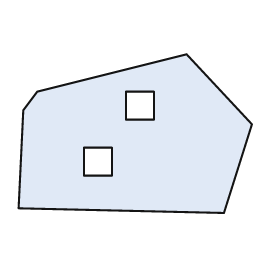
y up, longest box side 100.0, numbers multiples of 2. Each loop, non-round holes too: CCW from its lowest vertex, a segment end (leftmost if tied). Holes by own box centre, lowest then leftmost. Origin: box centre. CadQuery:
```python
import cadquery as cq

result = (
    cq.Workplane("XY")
    .moveTo(38.0, -34.0)
    .lineTo(50.0, 4.0)
    .lineTo(22.0, 34.0)
    .lineTo(-42.0, 18.0)
    .lineTo(-48.0, 10.0)
    .lineTo(-50.0, -32.0)
    .close()
    .moveTo(-22.0, -18.0)
    .lineTo(-10.0, -18.0)
    .lineTo(-10.0, -6.0)
    .lineTo(-22.0, -6.0)
    .close()
    .moveTo(-4.0, 6.0)
    .lineTo(8.0, 6.0)
    .lineTo(8.0, 18.0)
    .lineTo(-4.0, 18.0)
    .close()
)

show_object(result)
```